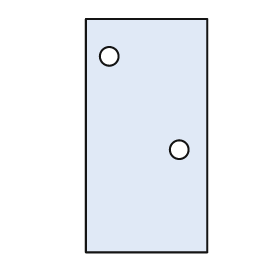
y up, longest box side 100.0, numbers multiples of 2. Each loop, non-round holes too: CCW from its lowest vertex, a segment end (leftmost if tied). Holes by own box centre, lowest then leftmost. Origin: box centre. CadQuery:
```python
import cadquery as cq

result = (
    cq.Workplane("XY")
    .moveTo(-26.0, -50.0)
    .lineTo(26.0, -50.0)
    .lineTo(26.0, 50.0)
    .lineTo(-26.0, 50.0)
    .close()
    .moveTo(14.0, -6.0)
    .circle(4.0)
    .moveTo(-16.0, 34.0)
    .circle(4.0)
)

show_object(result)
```